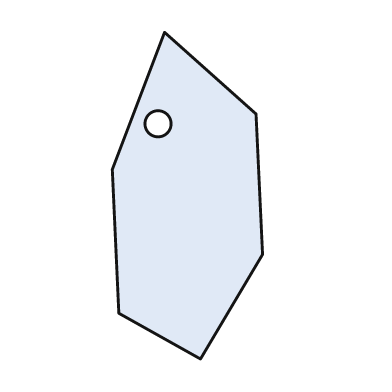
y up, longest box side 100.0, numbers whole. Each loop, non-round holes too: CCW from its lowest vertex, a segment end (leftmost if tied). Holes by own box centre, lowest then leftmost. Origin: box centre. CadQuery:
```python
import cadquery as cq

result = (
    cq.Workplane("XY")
    .moveTo(4.0, -50.0)
    .lineTo(23.0, -18.0)
    .lineTo(21.0, 25.0)
    .lineTo(-7.0, 50.0)
    .lineTo(-23.0, 8.0)
    .lineTo(-21.0, -36.0)
    .close()
    .moveTo(-9.0, 22.0)
    .circle(4.0)
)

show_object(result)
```